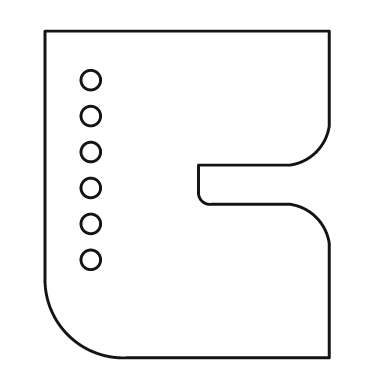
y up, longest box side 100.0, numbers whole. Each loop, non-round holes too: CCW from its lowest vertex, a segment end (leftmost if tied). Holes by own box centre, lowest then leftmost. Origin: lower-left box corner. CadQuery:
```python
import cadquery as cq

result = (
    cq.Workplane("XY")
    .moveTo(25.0, 0.0)
    .lineTo(87.0, 0.0)
    .lineTo(87.0, 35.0)
    .threePointArc((83.0, 43.0), (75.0, 47.0))
    .lineTo(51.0, 47.0)
    .threePointArc((48.0, 48.0), (47.0, 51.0))
    .lineTo(47.0, 59.0)
    .lineTo(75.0, 59.0)
    .threePointArc((83.0, 63.0), (87.0, 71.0))
    .lineTo(87.0, 100.0)
    .lineTo(0.0, 100.0)
    .lineTo(0.0, 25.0)
    .threePointArc((7.0, 7.0), (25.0, 0.0))
    .close()
    .moveTo(14.0, 30.0)
    .circle(3.0)
    .moveTo(14.0, 41.0)
    .circle(3.0)
    .moveTo(14.0, 52.0)
    .circle(3.0)
    .moveTo(14.0, 63.0)
    .circle(3.0)
    .moveTo(14.0, 74.0)
    .circle(3.0)
    .moveTo(14.0, 85.0)
    .circle(3.0)
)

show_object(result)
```